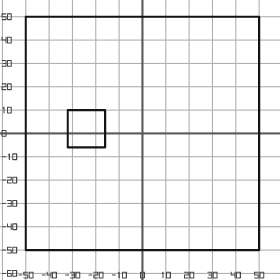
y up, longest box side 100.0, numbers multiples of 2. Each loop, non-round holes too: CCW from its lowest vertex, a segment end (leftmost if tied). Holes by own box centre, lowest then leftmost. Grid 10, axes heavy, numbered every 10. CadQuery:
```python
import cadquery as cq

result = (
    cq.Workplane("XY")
    .moveTo(-50.0, -50.0)
    .lineTo(50.0, -50.0)
    .lineTo(50.0, 50.0)
    .lineTo(-50.0, 50.0)
    .close()
    .moveTo(-32.0, -6.0)
    .lineTo(-16.0, -6.0)
    .lineTo(-16.0, 10.0)
    .lineTo(-32.0, 10.0)
    .close()
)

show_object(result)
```